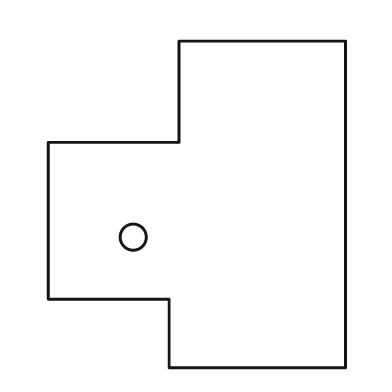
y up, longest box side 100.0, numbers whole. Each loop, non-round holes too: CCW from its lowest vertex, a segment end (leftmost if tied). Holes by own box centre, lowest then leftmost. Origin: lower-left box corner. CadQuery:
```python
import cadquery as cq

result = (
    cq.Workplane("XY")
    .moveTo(37.0, 0.0)
    .lineTo(91.0, 0.0)
    .lineTo(91.0, 100.0)
    .lineTo(40.0, 100.0)
    .lineTo(40.0, 69.0)
    .lineTo(0.0, 69.0)
    .lineTo(0.0, 21.0)
    .lineTo(37.0, 21.0)
    .close()
    .moveTo(26.0, 40.0)
    .circle(4.0)
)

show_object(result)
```